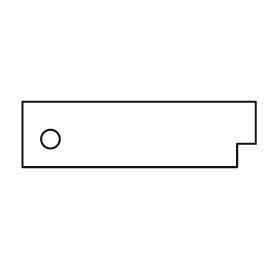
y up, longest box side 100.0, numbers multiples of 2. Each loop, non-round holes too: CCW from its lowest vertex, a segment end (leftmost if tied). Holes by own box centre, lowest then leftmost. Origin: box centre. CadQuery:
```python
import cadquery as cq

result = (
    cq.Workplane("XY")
    .moveTo(-50.0, -14.0)
    .lineTo(42.0, -14.0)
    .lineTo(42.0, -4.0)
    .lineTo(50.0, -4.0)
    .lineTo(50.0, 14.0)
    .lineTo(-50.0, 14.0)
    .close()
    .moveTo(-38.0, -2.0)
    .circle(4.0)
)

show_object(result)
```